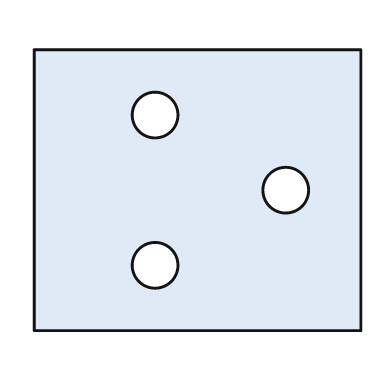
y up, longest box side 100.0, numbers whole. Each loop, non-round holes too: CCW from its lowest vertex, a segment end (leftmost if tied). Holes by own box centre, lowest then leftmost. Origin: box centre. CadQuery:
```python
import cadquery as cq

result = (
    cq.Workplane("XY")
    .moveTo(-50.0, -43.0)
    .lineTo(50.0, -43.0)
    .lineTo(50.0, 43.0)
    .lineTo(-50.0, 43.0)
    .close()
    .moveTo(-13.0, -23.0)
    .circle(7.0)
    .moveTo(27.0, 0.0)
    .circle(7.0)
    .moveTo(-13.0, 23.0)
    .circle(7.0)
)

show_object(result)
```